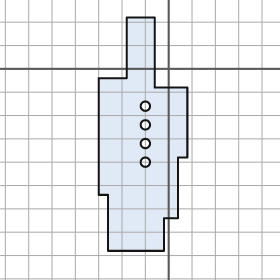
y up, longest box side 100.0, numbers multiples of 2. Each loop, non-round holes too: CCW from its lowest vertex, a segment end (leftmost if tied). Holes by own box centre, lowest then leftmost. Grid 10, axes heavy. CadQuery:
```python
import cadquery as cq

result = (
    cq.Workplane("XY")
    .moveTo(-26.0, -78.0)
    .lineTo(-2.0, -78.0)
    .lineTo(-2.0, -64.0)
    .lineTo(4.0, -64.0)
    .lineTo(4.0, -38.0)
    .lineTo(8.0, -38.0)
    .lineTo(8.0, -8.0)
    .lineTo(-6.0, -8.0)
    .lineTo(-6.0, 22.0)
    .lineTo(-18.0, 22.0)
    .lineTo(-18.0, -4.0)
    .lineTo(-30.0, -4.0)
    .lineTo(-30.0, -54.0)
    .lineTo(-26.0, -54.0)
    .close()
    .moveTo(-10.0, -40.0)
    .circle(2.0)
    .moveTo(-10.0, -32.0)
    .circle(2.0)
    .moveTo(-10.0, -24.0)
    .circle(2.0)
    .moveTo(-10.0, -16.0)
    .circle(2.0)
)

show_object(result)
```